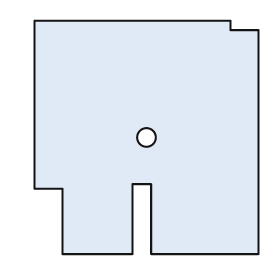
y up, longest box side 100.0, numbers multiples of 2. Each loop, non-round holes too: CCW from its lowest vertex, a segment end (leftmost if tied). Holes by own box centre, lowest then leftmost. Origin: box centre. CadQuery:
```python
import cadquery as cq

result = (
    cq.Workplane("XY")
    .moveTo(-36.0, -50.0)
    .lineTo(-6.0, -50.0)
    .lineTo(-6.0, -20.0)
    .lineTo(2.0, -20.0)
    .lineTo(2.0, -50.0)
    .lineTo(48.0, -50.0)
    .lineTo(48.0, 46.0)
    .lineTo(36.0, 46.0)
    .lineTo(36.0, 50.0)
    .lineTo(-48.0, 50.0)
    .lineTo(-48.0, -22.0)
    .lineTo(-36.0, -22.0)
    .close()
    .moveTo(0.0, 0.0)
    .circle(4.0)
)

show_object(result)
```